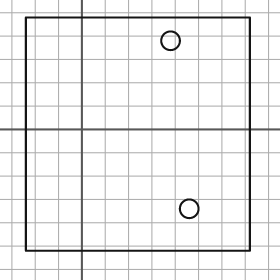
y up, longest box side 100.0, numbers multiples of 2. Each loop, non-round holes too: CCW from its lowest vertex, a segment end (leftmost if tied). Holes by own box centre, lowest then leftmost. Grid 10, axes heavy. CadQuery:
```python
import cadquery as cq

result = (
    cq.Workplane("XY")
    .moveTo(-24.0, -52.0)
    .lineTo(72.0, -52.0)
    .lineTo(72.0, 48.0)
    .lineTo(-24.0, 48.0)
    .close()
    .moveTo(46.0, -34.0)
    .circle(4.0)
    .moveTo(38.0, 38.0)
    .circle(4.0)
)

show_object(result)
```